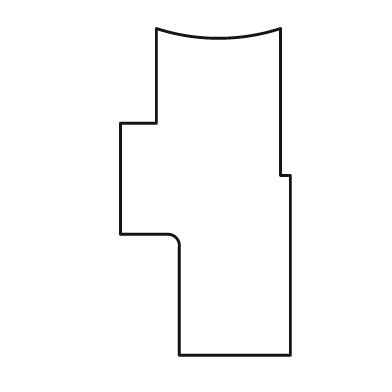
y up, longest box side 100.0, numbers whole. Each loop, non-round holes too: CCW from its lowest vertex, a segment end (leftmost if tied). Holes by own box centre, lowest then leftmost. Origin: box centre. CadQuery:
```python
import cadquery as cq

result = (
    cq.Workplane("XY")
    .moveTo(-8.0, -50.0)
    .lineTo(26.0, -50.0)
    .lineTo(26.0, 5.0)
    .lineTo(23.0, 5.0)
    .lineTo(23.0, 50.0)
    .threePointArc((4.0, 47.0), (-15.0, 50.0))
    .lineTo(-15.0, 21.0)
    .lineTo(-26.0, 21.0)
    .lineTo(-26.0, -13.0)
    .lineTo(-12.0, -13.0)
    .threePointArc((-9.0, -14.0), (-8.0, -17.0))
    .close()
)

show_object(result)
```